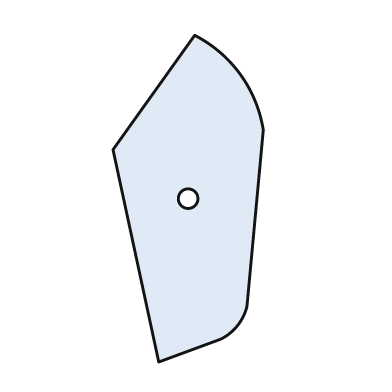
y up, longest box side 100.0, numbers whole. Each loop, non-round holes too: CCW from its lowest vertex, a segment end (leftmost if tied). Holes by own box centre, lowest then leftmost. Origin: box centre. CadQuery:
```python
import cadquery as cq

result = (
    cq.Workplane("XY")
    .moveTo(-9.0, -50.0)
    .lineTo(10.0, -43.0)
    .threePointArc((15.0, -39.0), (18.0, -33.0))
    .lineTo(23.0, 21.0)
    .threePointArc((16.0, 38.0), (2.0, 50.0))
    .lineTo(-23.0, 15.0)
    .close()
    .moveTo(0.0, 0.0)
    .circle(3.0)
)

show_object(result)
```